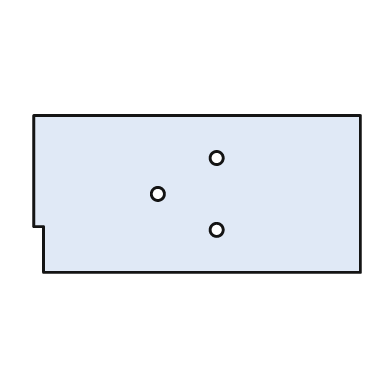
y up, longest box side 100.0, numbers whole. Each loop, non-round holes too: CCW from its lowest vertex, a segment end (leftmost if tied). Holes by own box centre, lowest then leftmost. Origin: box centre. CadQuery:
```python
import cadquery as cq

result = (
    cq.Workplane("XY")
    .moveTo(-47.0, -24.0)
    .lineTo(50.0, -24.0)
    .lineTo(50.0, 24.0)
    .lineTo(-50.0, 24.0)
    .lineTo(-50.0, -10.0)
    .lineTo(-47.0, -10.0)
    .close()
    .moveTo(6.0, -11.0)
    .circle(2.0)
    .moveTo(-12.0, 0.0)
    .circle(2.0)
    .moveTo(6.0, 11.0)
    .circle(2.0)
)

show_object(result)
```